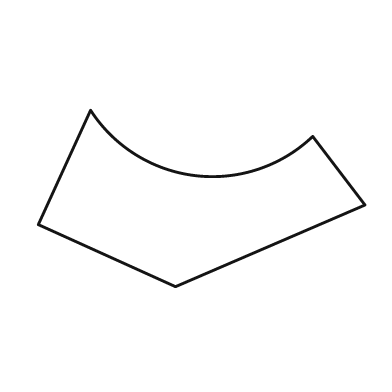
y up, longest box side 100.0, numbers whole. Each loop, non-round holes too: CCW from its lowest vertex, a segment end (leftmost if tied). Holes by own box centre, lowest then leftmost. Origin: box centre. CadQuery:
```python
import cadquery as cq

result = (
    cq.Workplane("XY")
    .moveTo(-8.0, -27.0)
    .lineTo(50.0, -2.0)
    .lineTo(34.0, 19.0)
    .threePointArc((-2.0, 7.0), (-34.0, 27.0))
    .lineTo(-50.0, -8.0)
    .close()
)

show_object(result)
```